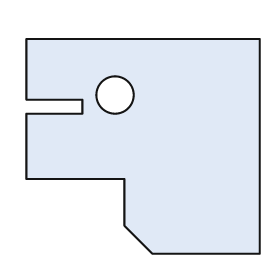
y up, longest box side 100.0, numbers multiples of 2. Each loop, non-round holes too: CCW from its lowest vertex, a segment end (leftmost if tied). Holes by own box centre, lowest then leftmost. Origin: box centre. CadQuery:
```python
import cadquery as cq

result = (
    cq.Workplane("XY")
    .moveTo(4.0, -46.0)
    .lineTo(50.0, -46.0)
    .lineTo(50.0, 46.0)
    .lineTo(-50.0, 46.0)
    .lineTo(-50.0, 20.0)
    .lineTo(-26.0, 20.0)
    .lineTo(-26.0, 14.0)
    .lineTo(-50.0, 14.0)
    .lineTo(-50.0, -14.0)
    .lineTo(-8.0, -14.0)
    .lineTo(-8.0, -34.0)
    .close()
    .moveTo(-12.0, 22.0)
    .circle(8.0)
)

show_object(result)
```